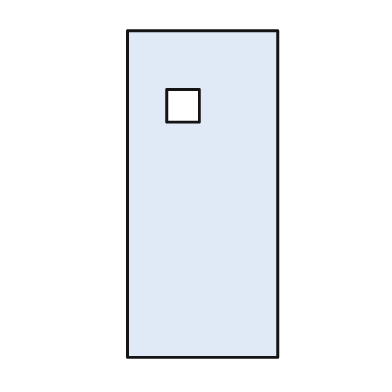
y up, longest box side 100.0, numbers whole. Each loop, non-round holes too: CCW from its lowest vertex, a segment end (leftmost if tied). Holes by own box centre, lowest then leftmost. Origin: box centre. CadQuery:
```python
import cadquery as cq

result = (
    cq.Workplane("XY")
    .moveTo(-23.0, -50.0)
    .lineTo(23.0, -50.0)
    .lineTo(23.0, 50.0)
    .lineTo(-23.0, 50.0)
    .close()
    .moveTo(-11.0, 22.0)
    .lineTo(-1.0, 22.0)
    .lineTo(-1.0, 32.0)
    .lineTo(-11.0, 32.0)
    .close()
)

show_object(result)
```